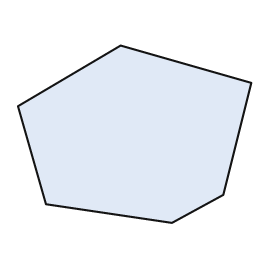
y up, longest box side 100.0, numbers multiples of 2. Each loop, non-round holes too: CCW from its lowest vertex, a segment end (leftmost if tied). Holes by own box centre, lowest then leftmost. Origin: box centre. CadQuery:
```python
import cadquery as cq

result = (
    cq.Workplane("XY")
    .moveTo(16.0, -38.0)
    .lineTo(38.0, -26.0)
    .lineTo(50.0, 22.0)
    .lineTo(-6.0, 38.0)
    .lineTo(-50.0, 12.0)
    .lineTo(-38.0, -30.0)
    .close()
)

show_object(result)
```